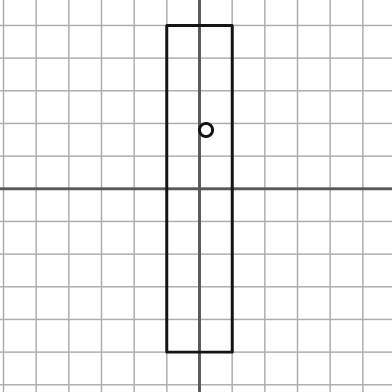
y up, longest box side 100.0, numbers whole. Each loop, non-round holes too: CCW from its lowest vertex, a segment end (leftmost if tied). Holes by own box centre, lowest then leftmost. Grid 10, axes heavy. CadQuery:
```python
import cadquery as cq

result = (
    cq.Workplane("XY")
    .moveTo(-10.0, -50.0)
    .lineTo(10.0, -50.0)
    .lineTo(10.0, 50.0)
    .lineTo(-10.0, 50.0)
    .close()
    .moveTo(2.0, 18.0)
    .circle(2.0)
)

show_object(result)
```